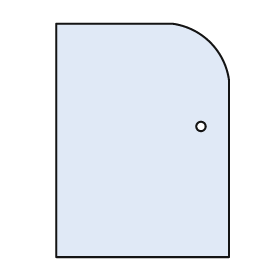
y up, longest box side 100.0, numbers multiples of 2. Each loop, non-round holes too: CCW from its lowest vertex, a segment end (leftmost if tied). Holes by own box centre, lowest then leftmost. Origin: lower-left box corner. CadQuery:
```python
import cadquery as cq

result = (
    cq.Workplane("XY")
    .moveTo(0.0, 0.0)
    .lineTo(74.0, 0.0)
    .lineTo(74.0, 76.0)
    .threePointArc((66.0, 92.0), (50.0, 100.0))
    .lineTo(0.0, 100.0)
    .close()
    .moveTo(62.0, 56.0)
    .circle(2.0)
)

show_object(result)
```